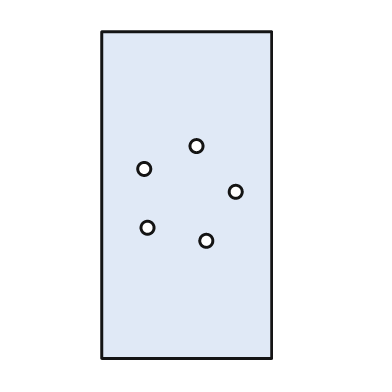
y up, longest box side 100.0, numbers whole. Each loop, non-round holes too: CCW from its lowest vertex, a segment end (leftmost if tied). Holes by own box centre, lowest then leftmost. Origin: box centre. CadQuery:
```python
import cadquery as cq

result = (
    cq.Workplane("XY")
    .moveTo(-26.0, -50.0)
    .lineTo(26.0, -50.0)
    .lineTo(26.0, 50.0)
    .lineTo(-26.0, 50.0)
    .close()
    .moveTo(6.0, -14.0)
    .circle(2.0)
    .moveTo(-12.0, -10.0)
    .circle(2.0)
    .moveTo(15.0, 1.0)
    .circle(2.0)
    .moveTo(-13.0, 8.0)
    .circle(2.0)
    .moveTo(3.0, 15.0)
    .circle(2.0)
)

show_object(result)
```